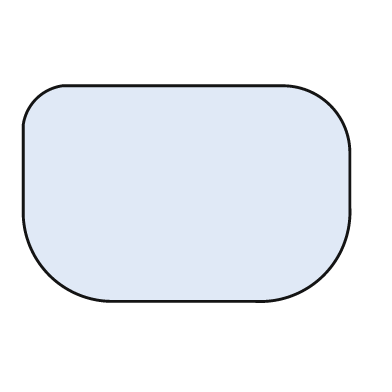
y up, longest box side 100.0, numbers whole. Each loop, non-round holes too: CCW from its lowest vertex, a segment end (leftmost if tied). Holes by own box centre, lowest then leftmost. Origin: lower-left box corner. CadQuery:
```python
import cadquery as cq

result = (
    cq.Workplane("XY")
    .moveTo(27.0, 0.0)
    .lineTo(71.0, 0.0)
    .threePointArc((92.0, 8.0), (100.0, 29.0))
    .lineTo(100.0, 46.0)
    .threePointArc((94.0, 60.0), (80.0, 66.0))
    .lineTo(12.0, 66.0)
    .threePointArc((4.0, 62.0), (0.0, 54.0))
    .lineTo(0.0, 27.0)
    .threePointArc((8.0, 8.0), (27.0, 0.0))
    .close()
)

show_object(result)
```